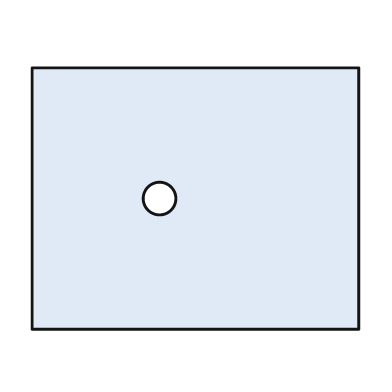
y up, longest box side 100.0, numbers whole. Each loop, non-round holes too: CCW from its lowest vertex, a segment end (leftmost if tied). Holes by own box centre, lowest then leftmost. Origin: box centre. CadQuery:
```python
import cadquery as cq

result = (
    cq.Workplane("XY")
    .moveTo(-50.0, -40.0)
    .lineTo(50.0, -40.0)
    .lineTo(50.0, 40.0)
    .lineTo(-50.0, 40.0)
    .close()
    .moveTo(-11.0, 0.0)
    .circle(5.0)
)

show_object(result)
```